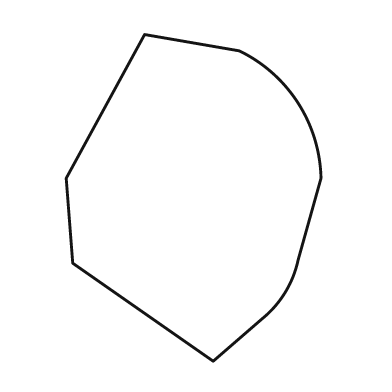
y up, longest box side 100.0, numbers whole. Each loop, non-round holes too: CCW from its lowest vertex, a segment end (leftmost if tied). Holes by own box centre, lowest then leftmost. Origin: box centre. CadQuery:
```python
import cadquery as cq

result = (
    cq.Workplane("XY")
    .moveTo(6.0, -50.0)
    .lineTo(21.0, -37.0)
    .threePointArc((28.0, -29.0), (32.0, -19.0))
    .lineTo(39.0, 6.0)
    .threePointArc((32.0, 29.0), (14.0, 45.0))
    .lineTo(-15.0, 50.0)
    .lineTo(-39.0, 6.0)
    .lineTo(-37.0, -20.0)
    .close()
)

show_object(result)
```